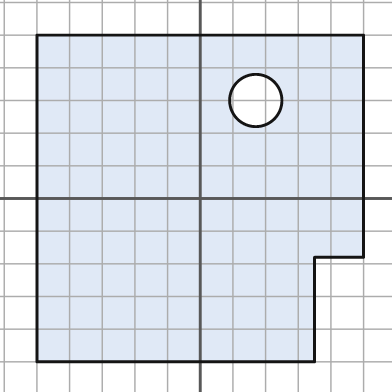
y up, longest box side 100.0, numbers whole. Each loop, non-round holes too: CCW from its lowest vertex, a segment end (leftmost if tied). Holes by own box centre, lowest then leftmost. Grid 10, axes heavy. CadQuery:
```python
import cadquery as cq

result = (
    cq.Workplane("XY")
    .moveTo(-50.0, -50.0)
    .lineTo(35.0, -50.0)
    .lineTo(35.0, -18.0)
    .lineTo(50.0, -18.0)
    .lineTo(50.0, 50.0)
    .lineTo(-50.0, 50.0)
    .close()
    .moveTo(17.0, 30.0)
    .circle(8.0)
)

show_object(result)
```